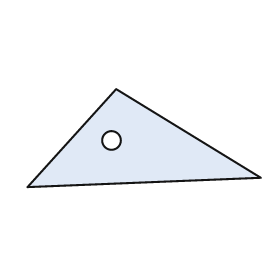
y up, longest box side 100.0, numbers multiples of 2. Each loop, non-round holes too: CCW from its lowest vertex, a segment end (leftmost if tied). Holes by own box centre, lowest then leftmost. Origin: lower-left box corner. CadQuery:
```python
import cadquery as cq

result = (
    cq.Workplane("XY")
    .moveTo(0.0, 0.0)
    .lineTo(100.0, 4.0)
    .lineTo(38.0, 42.0)
    .close()
    .moveTo(36.0, 20.0)
    .circle(4.0)
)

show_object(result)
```